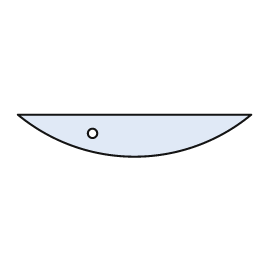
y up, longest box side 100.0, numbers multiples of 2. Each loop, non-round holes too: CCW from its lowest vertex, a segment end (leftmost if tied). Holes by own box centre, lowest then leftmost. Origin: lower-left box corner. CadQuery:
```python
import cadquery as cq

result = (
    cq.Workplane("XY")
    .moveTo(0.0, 18.0)
    .threePointArc((50.0, 0.0), (100.0, 18.0))
    .close()
    .moveTo(32.0, 10.0)
    .circle(2.0)
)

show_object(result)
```